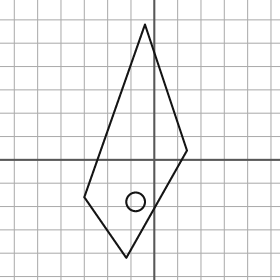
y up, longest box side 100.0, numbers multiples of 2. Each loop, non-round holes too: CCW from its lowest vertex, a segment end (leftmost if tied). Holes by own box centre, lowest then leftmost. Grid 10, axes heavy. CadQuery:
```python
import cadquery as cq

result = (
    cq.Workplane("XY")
    .moveTo(-12.0, -42.0)
    .lineTo(14.0, 4.0)
    .lineTo(-4.0, 58.0)
    .lineTo(-30.0, -16.0)
    .close()
    .moveTo(-8.0, -18.0)
    .circle(4.0)
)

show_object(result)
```